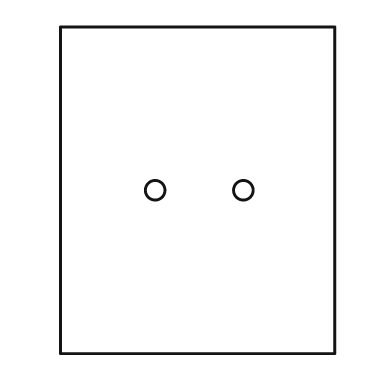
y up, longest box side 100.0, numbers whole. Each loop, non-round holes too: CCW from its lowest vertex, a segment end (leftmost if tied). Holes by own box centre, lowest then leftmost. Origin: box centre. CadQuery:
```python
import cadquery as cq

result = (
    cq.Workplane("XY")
    .moveTo(-42.0, -50.0)
    .lineTo(42.0, -50.0)
    .lineTo(42.0, 50.0)
    .lineTo(-42.0, 50.0)
    .close()
    .moveTo(-13.0, 0.0)
    .circle(3.0)
    .moveTo(14.0, 0.0)
    .circle(3.0)
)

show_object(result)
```